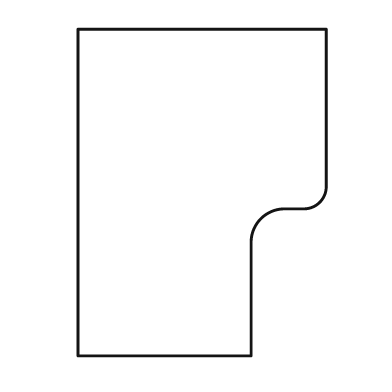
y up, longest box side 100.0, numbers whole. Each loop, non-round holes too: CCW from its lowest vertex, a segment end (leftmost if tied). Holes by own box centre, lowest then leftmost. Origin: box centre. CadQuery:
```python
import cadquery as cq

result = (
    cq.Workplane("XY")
    .moveTo(-38.0, -50.0)
    .lineTo(15.0, -50.0)
    .lineTo(15.0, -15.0)
    .threePointArc((18.0, -8.0), (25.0, -5.0))
    .lineTo(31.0, -5.0)
    .threePointArc((36.0, -3.0), (38.0, 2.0))
    .lineTo(38.0, 50.0)
    .lineTo(-38.0, 50.0)
    .close()
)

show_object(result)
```